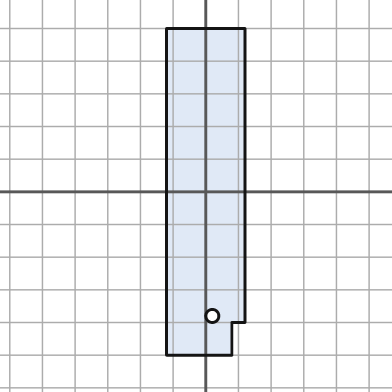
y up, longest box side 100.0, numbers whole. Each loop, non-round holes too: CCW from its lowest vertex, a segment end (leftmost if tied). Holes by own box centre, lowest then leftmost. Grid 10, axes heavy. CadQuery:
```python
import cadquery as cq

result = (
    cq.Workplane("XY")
    .moveTo(-12.0, -50.0)
    .lineTo(8.0, -50.0)
    .lineTo(8.0, -40.0)
    .lineTo(12.0, -40.0)
    .lineTo(12.0, 50.0)
    .lineTo(-12.0, 50.0)
    .close()
    .moveTo(2.0, -38.0)
    .circle(2.0)
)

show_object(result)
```